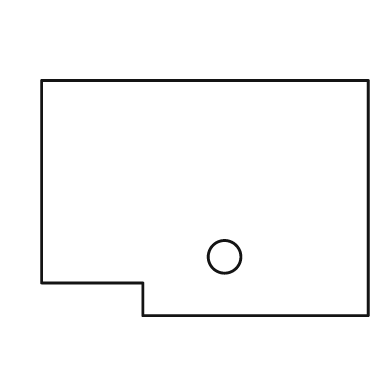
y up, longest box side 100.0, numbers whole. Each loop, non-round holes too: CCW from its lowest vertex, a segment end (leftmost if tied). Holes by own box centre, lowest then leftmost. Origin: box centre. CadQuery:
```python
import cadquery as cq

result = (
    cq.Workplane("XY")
    .moveTo(-19.0, -36.0)
    .lineTo(50.0, -36.0)
    .lineTo(50.0, 36.0)
    .lineTo(-50.0, 36.0)
    .lineTo(-50.0, -26.0)
    .lineTo(-19.0, -26.0)
    .close()
    .moveTo(6.0, -18.0)
    .circle(5.0)
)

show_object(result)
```